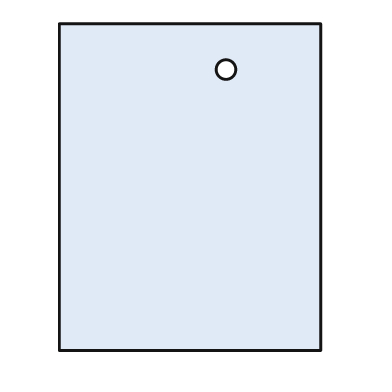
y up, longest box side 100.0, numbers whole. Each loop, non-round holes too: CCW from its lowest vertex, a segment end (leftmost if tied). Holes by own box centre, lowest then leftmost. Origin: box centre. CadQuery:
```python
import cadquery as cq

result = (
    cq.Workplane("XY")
    .moveTo(-40.0, -50.0)
    .lineTo(40.0, -50.0)
    .lineTo(40.0, 50.0)
    .lineTo(-40.0, 50.0)
    .close()
    .moveTo(11.0, 36.0)
    .circle(3.0)
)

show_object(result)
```